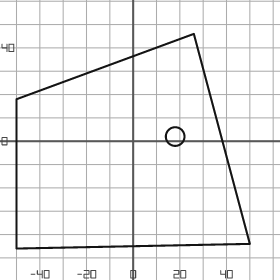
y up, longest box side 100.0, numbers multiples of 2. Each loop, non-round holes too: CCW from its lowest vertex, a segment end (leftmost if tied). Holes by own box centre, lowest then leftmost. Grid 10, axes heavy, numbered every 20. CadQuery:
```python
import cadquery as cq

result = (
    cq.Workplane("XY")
    .moveTo(-50.0, -46.0)
    .lineTo(50.0, -44.0)
    .lineTo(26.0, 46.0)
    .lineTo(-50.0, 18.0)
    .close()
    .moveTo(18.0, 2.0)
    .circle(4.0)
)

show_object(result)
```